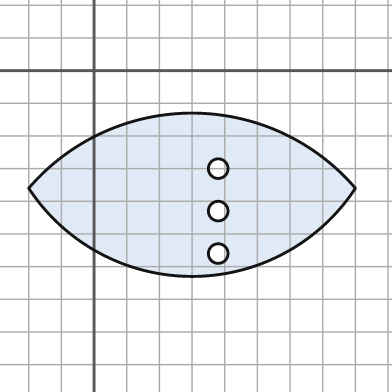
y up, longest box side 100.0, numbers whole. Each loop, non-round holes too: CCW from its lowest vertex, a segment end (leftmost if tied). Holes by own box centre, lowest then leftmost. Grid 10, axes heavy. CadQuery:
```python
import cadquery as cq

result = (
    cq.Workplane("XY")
    .moveTo(-20.0, -36.0)
    .threePointArc((30.0, -63.0), (80.0, -36.0))
    .threePointArc((30.0, -13.0), (-20.0, -36.0))
    .close()
    .moveTo(38.0, -56.0)
    .circle(3.0)
    .moveTo(38.0, -43.0)
    .circle(3.0)
    .moveTo(38.0, -30.0)
    .circle(3.0)
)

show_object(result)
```